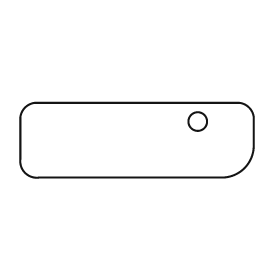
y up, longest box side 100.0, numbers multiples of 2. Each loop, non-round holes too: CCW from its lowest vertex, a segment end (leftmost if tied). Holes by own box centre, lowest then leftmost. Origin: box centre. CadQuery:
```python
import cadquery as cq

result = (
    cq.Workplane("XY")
    .moveTo(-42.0, -16.0)
    .lineTo(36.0, -16.0)
    .threePointArc((46.0, -12.0), (50.0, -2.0))
    .lineTo(50.0, 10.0)
    .threePointArc((48.0, 14.0), (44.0, 16.0))
    .lineTo(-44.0, 16.0)
    .threePointArc((-48.0, 14.0), (-50.0, 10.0))
    .lineTo(-50.0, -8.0)
    .threePointArc((-48.0, -14.0), (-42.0, -16.0))
    .close()
    .moveTo(26.0, 8.0)
    .circle(4.0)
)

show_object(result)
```